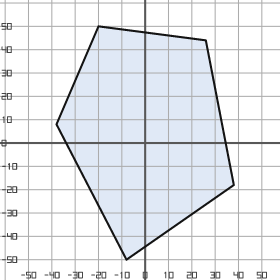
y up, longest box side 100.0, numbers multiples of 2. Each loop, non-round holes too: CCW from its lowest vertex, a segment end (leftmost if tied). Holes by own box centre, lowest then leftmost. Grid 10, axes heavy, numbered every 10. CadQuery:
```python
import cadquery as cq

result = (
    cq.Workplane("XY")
    .moveTo(-8.0, -50.0)
    .lineTo(38.0, -18.0)
    .lineTo(26.0, 44.0)
    .lineTo(-20.0, 50.0)
    .lineTo(-38.0, 8.0)
    .close()
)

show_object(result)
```